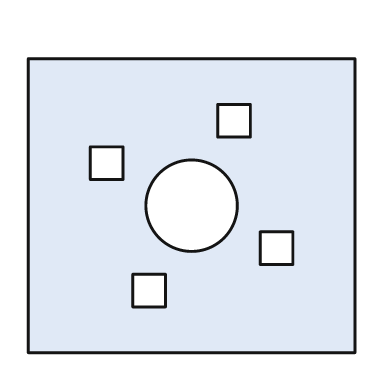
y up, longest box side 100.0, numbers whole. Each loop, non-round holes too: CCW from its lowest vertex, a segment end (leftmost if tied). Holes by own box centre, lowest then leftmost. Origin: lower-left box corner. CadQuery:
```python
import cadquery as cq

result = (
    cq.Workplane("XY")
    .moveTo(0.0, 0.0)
    .lineTo(100.0, 0.0)
    .lineTo(100.0, 90.0)
    .lineTo(0.0, 90.0)
    .close()
    .moveTo(32.0, 14.0)
    .lineTo(42.0, 14.0)
    .lineTo(42.0, 24.0)
    .lineTo(32.0, 24.0)
    .close()
    .moveTo(71.0, 27.0)
    .lineTo(81.0, 27.0)
    .lineTo(81.0, 37.0)
    .lineTo(71.0, 37.0)
    .close()
    .moveTo(50.0, 45.0)
    .circle(14.0)
    .moveTo(19.0, 53.0)
    .lineTo(29.0, 53.0)
    .lineTo(29.0, 63.0)
    .lineTo(19.0, 63.0)
    .close()
    .moveTo(58.0, 66.0)
    .lineTo(68.0, 66.0)
    .lineTo(68.0, 76.0)
    .lineTo(58.0, 76.0)
    .close()
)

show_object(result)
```